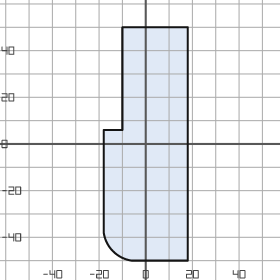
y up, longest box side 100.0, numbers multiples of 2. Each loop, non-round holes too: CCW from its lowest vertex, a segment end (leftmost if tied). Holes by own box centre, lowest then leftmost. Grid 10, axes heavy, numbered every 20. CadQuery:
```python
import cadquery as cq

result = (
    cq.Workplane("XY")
    .moveTo(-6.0, -50.0)
    .lineTo(18.0, -50.0)
    .lineTo(18.0, 50.0)
    .lineTo(-10.0, 50.0)
    .lineTo(-10.0, 6.0)
    .lineTo(-18.0, 6.0)
    .lineTo(-18.0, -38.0)
    .threePointArc((-14.0, -46.0), (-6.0, -50.0))
    .close()
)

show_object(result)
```